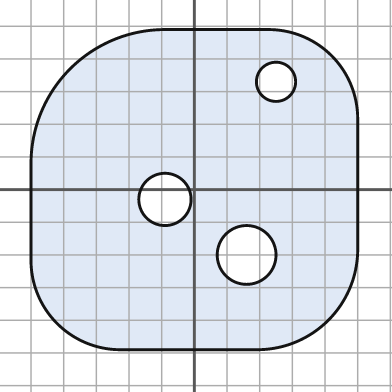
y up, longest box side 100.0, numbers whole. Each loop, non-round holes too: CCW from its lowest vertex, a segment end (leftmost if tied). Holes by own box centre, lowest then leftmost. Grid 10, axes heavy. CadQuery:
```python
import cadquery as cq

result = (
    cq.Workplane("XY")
    .moveTo(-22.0, -49.0)
    .lineTo(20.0, -49.0)
    .threePointArc((41.0, -40.0), (50.0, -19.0))
    .lineTo(50.0, 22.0)
    .threePointArc((42.0, 41.0), (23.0, 49.0))
    .lineTo(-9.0, 49.0)
    .threePointArc((-38.0, 37.0), (-50.0, 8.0))
    .lineTo(-50.0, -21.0)
    .threePointArc((-42.0, -41.0), (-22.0, -49.0))
    .close()
    .moveTo(16.0, -20.0)
    .circle(9.0)
    .moveTo(-9.0, -3.0)
    .circle(8.0)
    .moveTo(25.0, 33.0)
    .circle(6.0)
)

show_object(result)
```